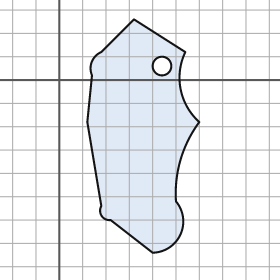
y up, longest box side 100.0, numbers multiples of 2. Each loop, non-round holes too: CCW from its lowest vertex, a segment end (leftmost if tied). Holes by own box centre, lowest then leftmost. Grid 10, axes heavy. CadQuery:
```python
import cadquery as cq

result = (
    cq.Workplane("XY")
    .moveTo(40.0, -74.0)
    .threePointArc((52.0, -66.0), (50.0, -52.0))
    .threePointArc((52.0, -34.0), (60.0, -18.0))
    .threePointArc((52.0, -4.0), (54.0, 12.0))
    .lineTo(32.0, 26.0)
    .lineTo(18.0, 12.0)
    .threePointArc((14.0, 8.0), (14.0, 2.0))
    .lineTo(12.0, -18.0)
    .lineTo(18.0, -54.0)
    .threePointArc((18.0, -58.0), (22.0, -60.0))
    .close()
    .moveTo(44.0, 6.0)
    .circle(4.0)
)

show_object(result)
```